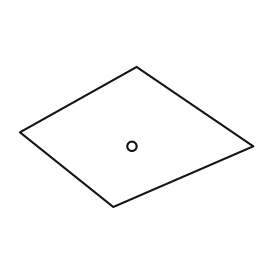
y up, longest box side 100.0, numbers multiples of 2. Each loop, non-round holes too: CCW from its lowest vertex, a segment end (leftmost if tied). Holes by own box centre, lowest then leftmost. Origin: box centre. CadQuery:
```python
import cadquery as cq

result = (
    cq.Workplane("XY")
    .moveTo(-10.0, -30.0)
    .lineTo(50.0, -4.0)
    .lineTo(0.0, 30.0)
    .lineTo(-50.0, 2.0)
    .close()
    .moveTo(-2.0, -4.0)
    .circle(2.0)
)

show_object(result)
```